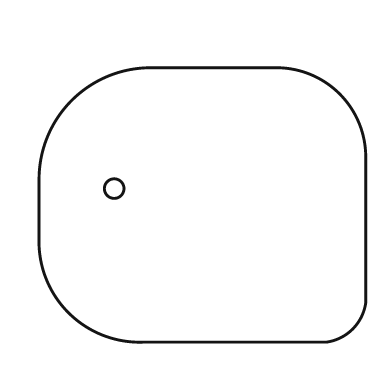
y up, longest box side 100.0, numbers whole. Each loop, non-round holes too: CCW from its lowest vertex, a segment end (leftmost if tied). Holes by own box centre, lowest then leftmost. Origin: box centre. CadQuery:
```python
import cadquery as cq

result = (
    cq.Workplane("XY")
    .moveTo(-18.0, -42.0)
    .lineTo(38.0, -42.0)
    .threePointArc((46.0, -38.0), (50.0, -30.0))
    .lineTo(50.0, 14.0)
    .threePointArc((42.0, 34.0), (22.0, 42.0))
    .lineTo(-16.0, 42.0)
    .threePointArc((-40.0, 32.0), (-50.0, 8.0))
    .lineTo(-50.0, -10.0)
    .threePointArc((-41.0, -33.0), (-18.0, -42.0))
    .close()
    .moveTo(-27.0, 5.0)
    .circle(3.0)
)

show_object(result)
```